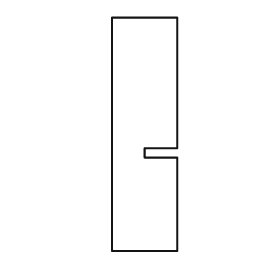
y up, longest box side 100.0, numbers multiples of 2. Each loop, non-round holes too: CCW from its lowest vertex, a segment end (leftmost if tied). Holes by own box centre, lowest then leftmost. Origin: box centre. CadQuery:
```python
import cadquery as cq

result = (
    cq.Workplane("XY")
    .moveTo(-14.0, -50.0)
    .lineTo(14.0, -50.0)
    .lineTo(14.0, -10.0)
    .lineTo(0.0, -10.0)
    .lineTo(0.0, -6.0)
    .lineTo(14.0, -6.0)
    .lineTo(14.0, 50.0)
    .lineTo(-14.0, 50.0)
    .close()
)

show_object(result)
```